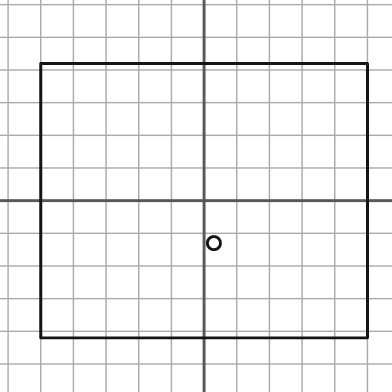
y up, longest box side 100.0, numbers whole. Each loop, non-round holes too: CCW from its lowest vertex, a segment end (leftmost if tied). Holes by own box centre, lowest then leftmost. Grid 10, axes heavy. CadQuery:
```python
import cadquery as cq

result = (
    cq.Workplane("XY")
    .moveTo(-50.0, -42.0)
    .lineTo(50.0, -42.0)
    .lineTo(50.0, 42.0)
    .lineTo(-50.0, 42.0)
    .close()
    .moveTo(3.0, -13.0)
    .circle(2.0)
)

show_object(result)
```